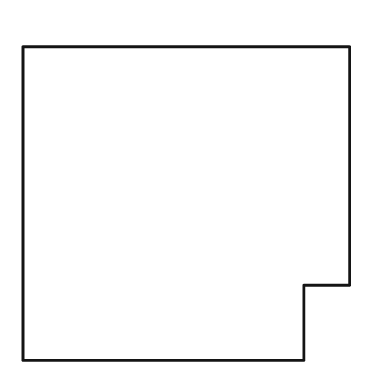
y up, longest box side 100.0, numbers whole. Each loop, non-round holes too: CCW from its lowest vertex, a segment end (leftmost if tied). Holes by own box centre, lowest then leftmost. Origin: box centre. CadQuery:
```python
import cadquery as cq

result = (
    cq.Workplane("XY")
    .moveTo(-50.0, -48.0)
    .lineTo(36.0, -48.0)
    .lineTo(36.0, -25.0)
    .lineTo(50.0, -25.0)
    .lineTo(50.0, 48.0)
    .lineTo(-50.0, 48.0)
    .close()
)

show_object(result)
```